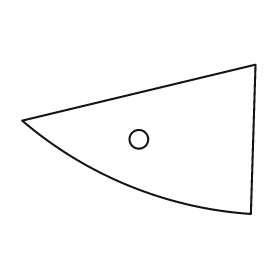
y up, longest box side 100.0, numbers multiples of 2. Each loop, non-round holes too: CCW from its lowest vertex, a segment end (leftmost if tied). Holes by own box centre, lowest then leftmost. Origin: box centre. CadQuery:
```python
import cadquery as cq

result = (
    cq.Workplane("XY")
    .moveTo(48.0, -32.0)
    .lineTo(50.0, 32.0)
    .lineTo(-50.0, 8.0)
    .threePointArc((-4.0, -20.0), (48.0, -32.0))
    .close()
    .moveTo(0.0, 0.0)
    .circle(4.0)
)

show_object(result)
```